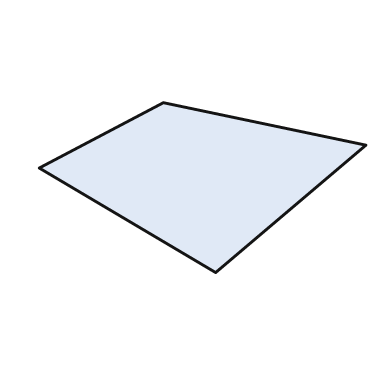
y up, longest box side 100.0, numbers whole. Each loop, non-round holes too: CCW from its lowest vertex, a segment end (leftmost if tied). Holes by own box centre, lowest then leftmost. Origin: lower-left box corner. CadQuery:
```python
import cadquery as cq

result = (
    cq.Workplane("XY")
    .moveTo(54.0, 0.0)
    .lineTo(100.0, 39.0)
    .lineTo(38.0, 52.0)
    .lineTo(0.0, 32.0)
    .close()
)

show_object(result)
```